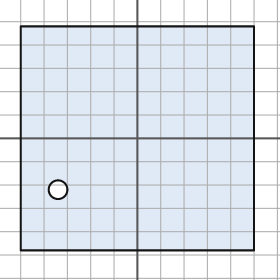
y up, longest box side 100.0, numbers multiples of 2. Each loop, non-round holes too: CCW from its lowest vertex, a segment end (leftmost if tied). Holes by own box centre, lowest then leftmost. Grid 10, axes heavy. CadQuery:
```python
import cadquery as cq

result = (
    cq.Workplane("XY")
    .moveTo(-50.0, -48.0)
    .lineTo(50.0, -48.0)
    .lineTo(50.0, 48.0)
    .lineTo(-50.0, 48.0)
    .close()
    .moveTo(-34.0, -22.0)
    .circle(4.0)
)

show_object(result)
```